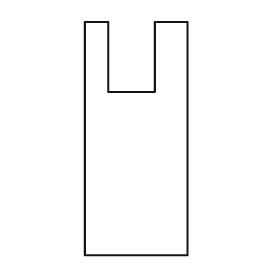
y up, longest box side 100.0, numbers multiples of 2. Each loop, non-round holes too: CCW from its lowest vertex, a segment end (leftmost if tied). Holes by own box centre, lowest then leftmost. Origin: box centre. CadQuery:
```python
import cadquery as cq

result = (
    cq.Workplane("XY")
    .moveTo(-22.0, -50.0)
    .lineTo(22.0, -50.0)
    .lineTo(22.0, 50.0)
    .lineTo(8.0, 50.0)
    .lineTo(8.0, 20.0)
    .lineTo(-12.0, 20.0)
    .lineTo(-12.0, 50.0)
    .lineTo(-22.0, 50.0)
    .close()
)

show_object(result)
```